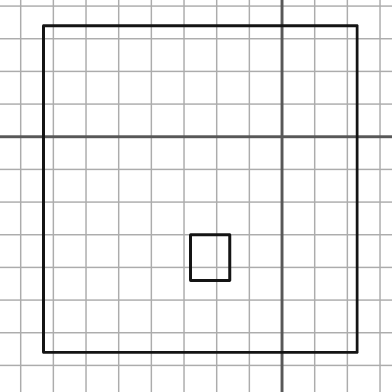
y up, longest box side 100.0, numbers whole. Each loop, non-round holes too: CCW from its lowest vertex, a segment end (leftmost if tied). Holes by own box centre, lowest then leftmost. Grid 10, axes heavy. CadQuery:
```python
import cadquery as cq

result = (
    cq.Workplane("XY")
    .moveTo(-73.0, -66.0)
    .lineTo(23.0, -66.0)
    .lineTo(23.0, 34.0)
    .lineTo(-73.0, 34.0)
    .close()
    .moveTo(-28.0, -44.0)
    .lineTo(-16.0, -44.0)
    .lineTo(-16.0, -30.0)
    .lineTo(-28.0, -30.0)
    .close()
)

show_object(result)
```